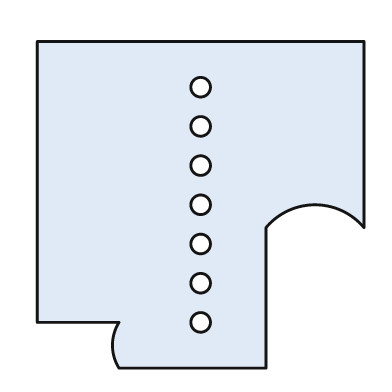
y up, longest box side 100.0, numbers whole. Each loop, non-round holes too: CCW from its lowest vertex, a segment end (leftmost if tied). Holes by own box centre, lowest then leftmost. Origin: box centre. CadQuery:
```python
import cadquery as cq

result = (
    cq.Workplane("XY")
    .moveTo(-25.0, -50.0)
    .lineTo(20.0, -50.0)
    .lineTo(20.0, -7.0)
    .threePointArc((35.0, 0.0), (50.0, -7.0))
    .lineTo(50.0, 50.0)
    .lineTo(-50.0, 50.0)
    .lineTo(-50.0, -36.0)
    .lineTo(-25.0, -36.0)
    .threePointArc((-27.0, -43.0), (-25.0, -50.0))
    .close()
    .moveTo(0.0, -36.0)
    .circle(3.0)
    .moveTo(0.0, -24.0)
    .circle(3.0)
    .moveTo(0.0, -12.0)
    .circle(3.0)
    .moveTo(0.0, 0.0)
    .circle(3.0)
    .moveTo(0.0, 12.0)
    .circle(3.0)
    .moveTo(0.0, 24.0)
    .circle(3.0)
    .moveTo(0.0, 36.0)
    .circle(3.0)
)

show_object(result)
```